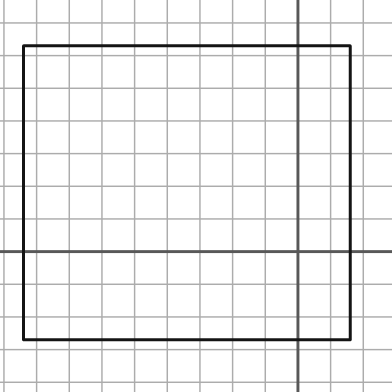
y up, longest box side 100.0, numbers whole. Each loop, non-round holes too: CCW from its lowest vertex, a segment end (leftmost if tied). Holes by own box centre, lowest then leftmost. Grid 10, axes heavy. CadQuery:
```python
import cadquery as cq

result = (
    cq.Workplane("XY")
    .moveTo(-84.0, -27.0)
    .lineTo(16.0, -27.0)
    .lineTo(16.0, 63.0)
    .lineTo(-84.0, 63.0)
    .close()
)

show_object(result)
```